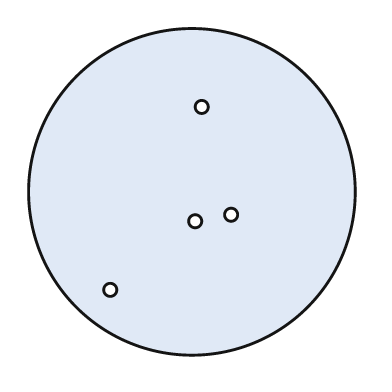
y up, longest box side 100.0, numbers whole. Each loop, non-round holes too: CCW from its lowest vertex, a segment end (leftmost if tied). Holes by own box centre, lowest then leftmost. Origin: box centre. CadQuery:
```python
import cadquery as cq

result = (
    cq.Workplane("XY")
    .moveTo(0.0, 0.0)
    .circle(50.0)
    .moveTo(-25.0, -30.0)
    .circle(2.0)
    .moveTo(1.0, -9.0)
    .circle(2.0)
    .moveTo(12.0, -7.0)
    .circle(2.0)
    .moveTo(3.0, 26.0)
    .circle(2.0)
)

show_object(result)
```